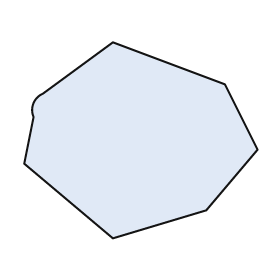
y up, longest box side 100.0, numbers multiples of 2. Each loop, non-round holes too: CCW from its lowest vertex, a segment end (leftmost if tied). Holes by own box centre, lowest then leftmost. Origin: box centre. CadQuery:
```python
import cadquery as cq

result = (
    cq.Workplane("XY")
    .moveTo(-12.0, -42.0)
    .lineTo(28.0, -30.0)
    .lineTo(50.0, -4.0)
    .lineTo(36.0, 24.0)
    .lineTo(-12.0, 42.0)
    .lineTo(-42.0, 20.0)
    .threePointArc((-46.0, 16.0), (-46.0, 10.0))
    .lineTo(-50.0, -10.0)
    .close()
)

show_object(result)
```